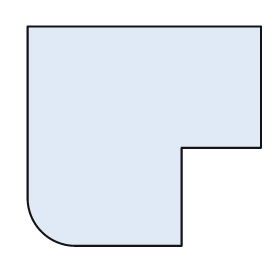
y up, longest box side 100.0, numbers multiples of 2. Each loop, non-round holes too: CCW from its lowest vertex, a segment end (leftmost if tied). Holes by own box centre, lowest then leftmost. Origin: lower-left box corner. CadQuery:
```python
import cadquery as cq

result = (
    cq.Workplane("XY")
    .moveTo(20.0, 0.0)
    .lineTo(66.0, 0.0)
    .lineTo(66.0, 42.0)
    .lineTo(100.0, 42.0)
    .lineTo(100.0, 94.0)
    .lineTo(0.0, 94.0)
    .lineTo(0.0, 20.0)
    .threePointArc((6.0, 6.0), (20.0, 0.0))
    .close()
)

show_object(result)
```